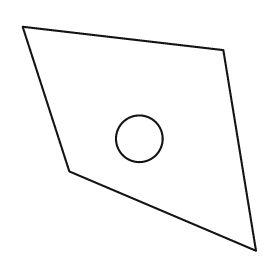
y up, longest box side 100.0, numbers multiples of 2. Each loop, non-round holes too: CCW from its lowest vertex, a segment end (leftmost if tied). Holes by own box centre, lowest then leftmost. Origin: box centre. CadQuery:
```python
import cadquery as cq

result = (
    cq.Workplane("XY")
    .moveTo(50.0, -48.0)
    .lineTo(36.0, 38.0)
    .lineTo(-50.0, 48.0)
    .lineTo(-30.0, -14.0)
    .close()
    .moveTo(0.0, 0.0)
    .circle(10.0)
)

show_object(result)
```